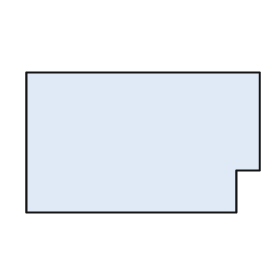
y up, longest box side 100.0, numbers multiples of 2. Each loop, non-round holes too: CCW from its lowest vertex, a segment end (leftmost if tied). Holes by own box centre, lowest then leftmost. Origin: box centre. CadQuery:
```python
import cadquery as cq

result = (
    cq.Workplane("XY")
    .moveTo(-50.0, -30.0)
    .lineTo(40.0, -30.0)
    .lineTo(40.0, -12.0)
    .lineTo(50.0, -12.0)
    .lineTo(50.0, 30.0)
    .lineTo(-50.0, 30.0)
    .close()
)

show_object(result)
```